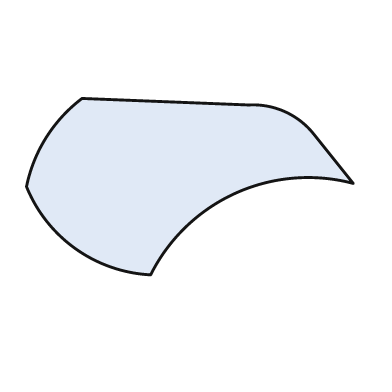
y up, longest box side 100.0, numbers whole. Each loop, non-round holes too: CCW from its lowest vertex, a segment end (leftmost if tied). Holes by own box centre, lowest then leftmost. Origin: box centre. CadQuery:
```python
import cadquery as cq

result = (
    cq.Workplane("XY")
    .moveTo(-12.0, -27.0)
    .threePointArc((14.0, -2.0), (50.0, 1.0))
    .lineTo(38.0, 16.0)
    .threePointArc((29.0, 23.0), (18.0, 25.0))
    .lineTo(-33.0, 27.0)
    .threePointArc((-44.0, 15.0), (-50.0, 0.0))
    .threePointArc((-35.0, -19.0), (-12.0, -27.0))
    .close()
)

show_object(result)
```